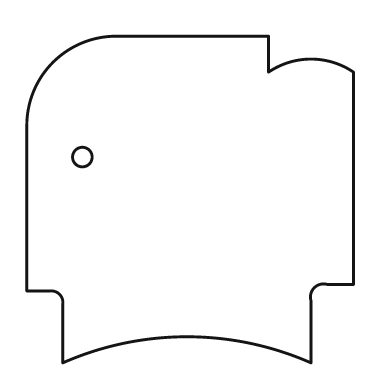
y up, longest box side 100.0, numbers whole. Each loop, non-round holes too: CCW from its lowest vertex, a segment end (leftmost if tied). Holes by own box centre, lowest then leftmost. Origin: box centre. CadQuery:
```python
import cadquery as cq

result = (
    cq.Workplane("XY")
    .moveTo(-39.0, -50.0)
    .threePointArc((-1.0, -42.0), (37.0, -50.0))
    .lineTo(37.0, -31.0)
    .threePointArc((38.0, -27.0), (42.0, -26.0))
    .lineTo(50.0, -26.0)
    .lineTo(50.0, 39.0)
    .threePointArc((37.0, 43.0), (24.0, 39.0))
    .lineTo(24.0, 50.0)
    .lineTo(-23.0, 50.0)
    .threePointArc((-42.0, 42.0), (-50.0, 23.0))
    .lineTo(-50.0, -28.0)
    .lineTo(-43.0, -28.0)
    .threePointArc((-40.0, -29.0), (-39.0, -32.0))
    .close()
    .moveTo(-33.0, 13.0)
    .circle(3.0)
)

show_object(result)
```